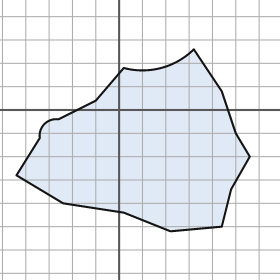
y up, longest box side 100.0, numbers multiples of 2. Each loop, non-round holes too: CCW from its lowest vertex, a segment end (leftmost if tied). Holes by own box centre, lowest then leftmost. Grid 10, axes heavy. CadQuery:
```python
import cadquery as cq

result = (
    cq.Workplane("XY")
    .moveTo(22.0, -52.0)
    .lineTo(44.0, -50.0)
    .lineTo(48.0, -34.0)
    .lineTo(56.0, -20.0)
    .lineTo(50.0, -10.0)
    .lineTo(44.0, 8.0)
    .lineTo(32.0, 26.0)
    .threePointArc((18.0, 18.0), (2.0, 18.0))
    .lineTo(-10.0, 4.0)
    .lineTo(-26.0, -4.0)
    .threePointArc((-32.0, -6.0), (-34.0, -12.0))
    .lineTo(-44.0, -28.0)
    .lineTo(-24.0, -40.0)
    .lineTo(2.0, -44.0)
    .close()
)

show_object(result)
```